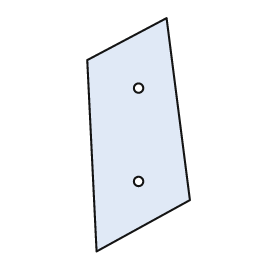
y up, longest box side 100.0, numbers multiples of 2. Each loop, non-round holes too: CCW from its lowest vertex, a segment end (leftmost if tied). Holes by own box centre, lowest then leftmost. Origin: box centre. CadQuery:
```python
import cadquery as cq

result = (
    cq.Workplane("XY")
    .moveTo(-18.0, -50.0)
    .lineTo(22.0, -28.0)
    .lineTo(12.0, 50.0)
    .lineTo(-22.0, 32.0)
    .close()
    .moveTo(0.0, -20.0)
    .circle(2.0)
    .moveTo(0.0, 20.0)
    .circle(2.0)
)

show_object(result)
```